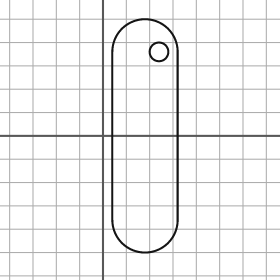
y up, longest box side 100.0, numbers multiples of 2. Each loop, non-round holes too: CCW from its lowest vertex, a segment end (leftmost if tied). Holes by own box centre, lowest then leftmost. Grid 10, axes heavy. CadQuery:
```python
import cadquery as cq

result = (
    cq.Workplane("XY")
    .moveTo(4.0, -36.0)
    .threePointArc((18.0, -50.0), (32.0, -36.0))
    .lineTo(32.0, 36.0)
    .threePointArc((18.0, 50.0), (4.0, 36.0))
    .close()
    .moveTo(24.0, 36.0)
    .circle(4.0)
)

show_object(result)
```